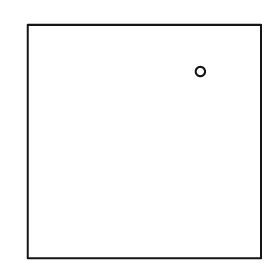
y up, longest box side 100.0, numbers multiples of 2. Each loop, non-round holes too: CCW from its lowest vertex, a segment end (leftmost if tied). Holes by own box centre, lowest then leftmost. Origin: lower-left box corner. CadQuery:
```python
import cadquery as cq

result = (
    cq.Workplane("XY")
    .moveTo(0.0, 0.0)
    .lineTo(100.0, 0.0)
    .lineTo(100.0, 100.0)
    .lineTo(0.0, 100.0)
    .close()
    .moveTo(74.0, 80.0)
    .circle(2.0)
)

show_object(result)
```